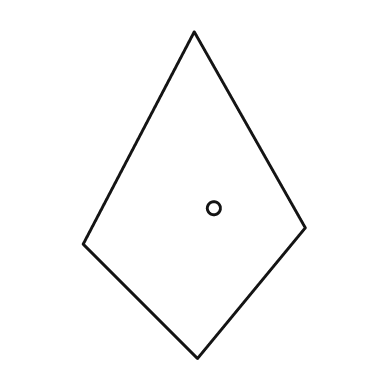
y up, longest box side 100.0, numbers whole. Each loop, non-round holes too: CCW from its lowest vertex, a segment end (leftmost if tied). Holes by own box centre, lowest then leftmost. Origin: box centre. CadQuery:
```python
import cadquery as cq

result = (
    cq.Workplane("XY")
    .moveTo(1.0, -50.0)
    .lineTo(34.0, -10.0)
    .lineTo(0.0, 50.0)
    .lineTo(-34.0, -15.0)
    .close()
    .moveTo(6.0, -4.0)
    .circle(2.0)
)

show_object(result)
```